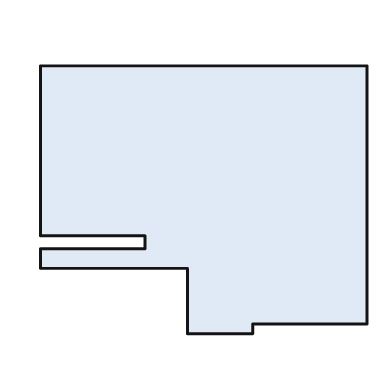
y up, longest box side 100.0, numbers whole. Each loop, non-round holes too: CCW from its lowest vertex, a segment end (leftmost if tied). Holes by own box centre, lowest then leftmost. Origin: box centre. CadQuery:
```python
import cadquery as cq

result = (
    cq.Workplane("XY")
    .moveTo(-5.0, -41.0)
    .lineTo(15.0, -41.0)
    .lineTo(15.0, -38.0)
    .lineTo(50.0, -38.0)
    .lineTo(50.0, 41.0)
    .lineTo(-50.0, 41.0)
    .lineTo(-50.0, -11.0)
    .lineTo(-18.0, -11.0)
    .lineTo(-18.0, -15.0)
    .lineTo(-50.0, -15.0)
    .lineTo(-50.0, -21.0)
    .lineTo(-5.0, -21.0)
    .close()
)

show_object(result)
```